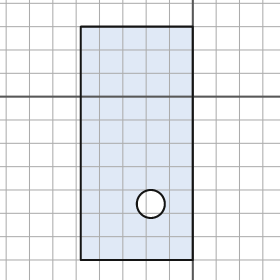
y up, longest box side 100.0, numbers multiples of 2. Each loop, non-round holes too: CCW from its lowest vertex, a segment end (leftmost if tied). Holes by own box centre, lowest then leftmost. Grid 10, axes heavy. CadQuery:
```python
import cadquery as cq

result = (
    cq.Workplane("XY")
    .moveTo(-48.0, -70.0)
    .lineTo(0.0, -70.0)
    .lineTo(0.0, 30.0)
    .lineTo(-48.0, 30.0)
    .close()
    .moveTo(-18.0, -46.0)
    .circle(6.0)
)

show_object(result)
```